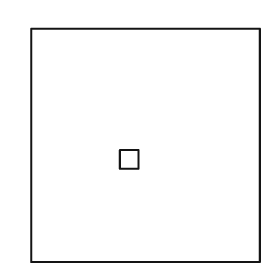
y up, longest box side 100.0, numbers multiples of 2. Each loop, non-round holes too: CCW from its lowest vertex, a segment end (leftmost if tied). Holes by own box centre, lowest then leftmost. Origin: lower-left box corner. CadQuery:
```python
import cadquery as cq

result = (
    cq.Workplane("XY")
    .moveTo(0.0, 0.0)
    .lineTo(98.0, 0.0)
    .lineTo(98.0, 100.0)
    .lineTo(0.0, 100.0)
    .close()
    .moveTo(38.0, 40.0)
    .lineTo(46.0, 40.0)
    .lineTo(46.0, 48.0)
    .lineTo(38.0, 48.0)
    .close()
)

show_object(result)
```